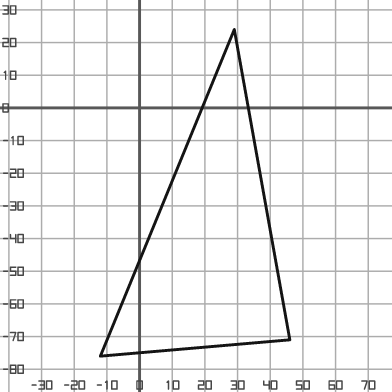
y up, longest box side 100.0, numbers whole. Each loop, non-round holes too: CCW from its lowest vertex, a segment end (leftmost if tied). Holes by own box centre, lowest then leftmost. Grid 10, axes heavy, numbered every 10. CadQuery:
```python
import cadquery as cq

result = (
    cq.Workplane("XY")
    .moveTo(-12.0, -76.0)
    .lineTo(46.0, -71.0)
    .lineTo(29.0, 24.0)
    .close()
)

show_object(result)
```